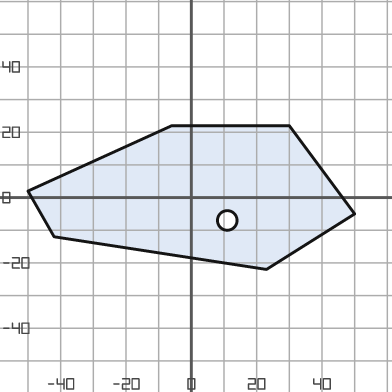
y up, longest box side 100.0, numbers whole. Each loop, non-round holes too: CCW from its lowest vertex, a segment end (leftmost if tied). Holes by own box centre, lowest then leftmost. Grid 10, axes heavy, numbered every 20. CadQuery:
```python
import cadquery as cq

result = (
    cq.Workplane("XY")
    .moveTo(23.0, -22.0)
    .lineTo(50.0, -5.0)
    .lineTo(30.0, 22.0)
    .lineTo(-6.0, 22.0)
    .lineTo(-50.0, 2.0)
    .lineTo(-42.0, -12.0)
    .close()
    .moveTo(11.0, -7.0)
    .circle(3.0)
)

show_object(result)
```